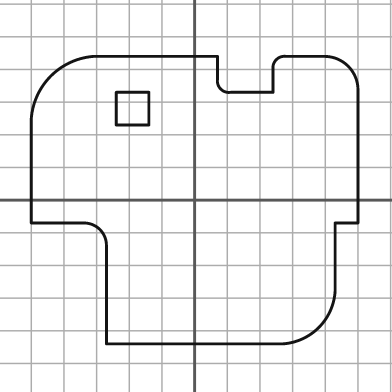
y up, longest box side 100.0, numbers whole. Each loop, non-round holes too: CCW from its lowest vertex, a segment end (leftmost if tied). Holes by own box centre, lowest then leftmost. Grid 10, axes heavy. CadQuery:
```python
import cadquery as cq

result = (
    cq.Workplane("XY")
    .moveTo(-27.0, -44.0)
    .lineTo(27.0, -44.0)
    .threePointArc((38.0, -39.0), (43.0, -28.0))
    .lineTo(43.0, -7.0)
    .lineTo(50.0, -7.0)
    .lineTo(50.0, 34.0)
    .threePointArc((47.0, 41.0), (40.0, 44.0))
    .lineTo(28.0, 44.0)
    .threePointArc((25.0, 43.0), (24.0, 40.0))
    .lineTo(24.0, 33.0)
    .lineTo(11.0, 33.0)
    .threePointArc((8.0, 34.0), (7.0, 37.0))
    .lineTo(7.0, 44.0)
    .lineTo(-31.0, 44.0)
    .threePointArc((-44.0, 38.0), (-50.0, 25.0))
    .lineTo(-50.0, -7.0)
    .lineTo(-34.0, -7.0)
    .threePointArc((-29.0, -9.0), (-27.0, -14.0))
    .close()
    .moveTo(-24.0, 23.0)
    .lineTo(-14.0, 23.0)
    .lineTo(-14.0, 33.0)
    .lineTo(-24.0, 33.0)
    .close()
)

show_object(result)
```